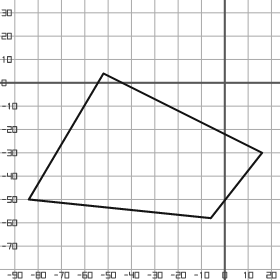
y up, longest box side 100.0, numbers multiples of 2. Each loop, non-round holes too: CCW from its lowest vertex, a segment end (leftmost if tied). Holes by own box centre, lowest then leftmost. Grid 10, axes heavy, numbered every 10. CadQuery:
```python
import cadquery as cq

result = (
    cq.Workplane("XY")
    .moveTo(-6.0, -58.0)
    .lineTo(16.0, -30.0)
    .lineTo(-52.0, 4.0)
    .lineTo(-84.0, -50.0)
    .close()
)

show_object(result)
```